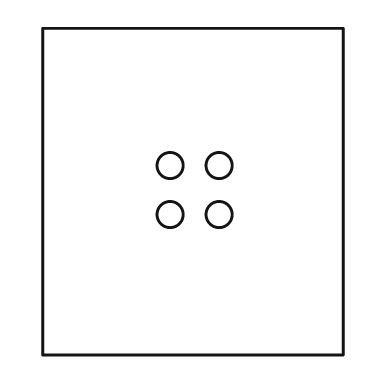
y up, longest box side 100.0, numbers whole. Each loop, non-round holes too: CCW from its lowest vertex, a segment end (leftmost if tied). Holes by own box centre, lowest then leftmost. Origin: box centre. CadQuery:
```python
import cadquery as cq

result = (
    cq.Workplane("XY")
    .moveTo(-46.0, -50.0)
    .lineTo(46.0, -50.0)
    .lineTo(46.0, 50.0)
    .lineTo(-46.0, 50.0)
    .close()
    .moveTo(-7.0, -7.0)
    .circle(4.0)
    .moveTo(8.0, -7.0)
    .circle(4.0)
    .moveTo(-7.0, 8.0)
    .circle(4.0)
    .moveTo(8.0, 8.0)
    .circle(4.0)
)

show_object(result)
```